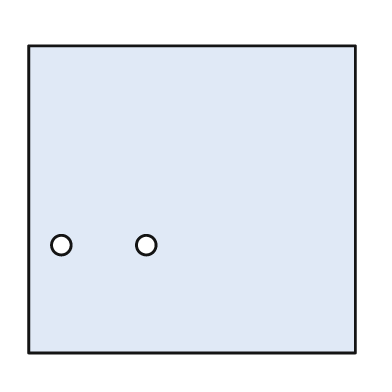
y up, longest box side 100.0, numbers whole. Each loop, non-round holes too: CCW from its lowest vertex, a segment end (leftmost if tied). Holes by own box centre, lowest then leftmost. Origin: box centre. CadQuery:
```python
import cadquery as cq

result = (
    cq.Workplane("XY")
    .moveTo(-50.0, -47.0)
    .lineTo(50.0, -47.0)
    .lineTo(50.0, 47.0)
    .lineTo(-50.0, 47.0)
    .close()
    .moveTo(-40.0, -14.0)
    .circle(3.0)
    .moveTo(-14.0, -14.0)
    .circle(3.0)
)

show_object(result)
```